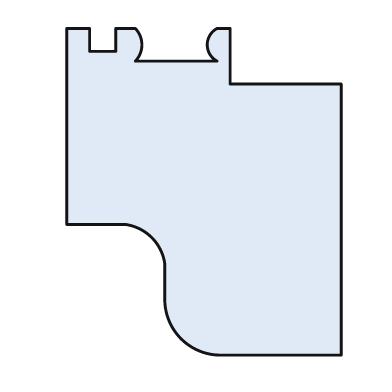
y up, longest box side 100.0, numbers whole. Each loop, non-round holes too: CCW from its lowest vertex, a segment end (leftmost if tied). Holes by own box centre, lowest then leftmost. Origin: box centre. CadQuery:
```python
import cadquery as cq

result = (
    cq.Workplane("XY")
    .moveTo(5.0, -50.0)
    .lineTo(42.0, -50.0)
    .lineTo(42.0, 33.0)
    .lineTo(8.0, 33.0)
    .lineTo(8.0, 50.0)
    .lineTo(4.0, 50.0)
    .threePointArc((1.0, 45.0), (4.0, 40.0))
    .lineTo(-21.0, 40.0)
    .threePointArc((-19.0, 45.0), (-21.0, 50.0))
    .lineTo(-27.0, 50.0)
    .lineTo(-27.0, 43.0)
    .lineTo(-35.0, 43.0)
    .lineTo(-35.0, 50.0)
    .lineTo(-42.0, 50.0)
    .lineTo(-42.0, -10.0)
    .lineTo(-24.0, -10.0)
    .threePointArc((-16.0, -14.0), (-12.0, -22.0))
    .lineTo(-12.0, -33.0)
    .threePointArc((-7.0, -45.0), (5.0, -50.0))
    .close()
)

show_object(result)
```